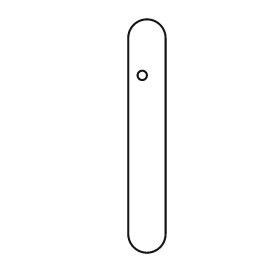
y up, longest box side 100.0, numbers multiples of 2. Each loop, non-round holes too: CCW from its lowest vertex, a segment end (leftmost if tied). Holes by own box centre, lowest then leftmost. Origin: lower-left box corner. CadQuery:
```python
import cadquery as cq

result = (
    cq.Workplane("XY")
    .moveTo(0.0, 8.0)
    .threePointArc((8.0, 0.0), (16.0, 8.0))
    .lineTo(16.0, 92.0)
    .threePointArc((8.0, 100.0), (0.0, 92.0))
    .close()
    .moveTo(6.0, 76.0)
    .circle(2.0)
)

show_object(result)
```